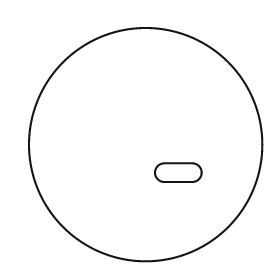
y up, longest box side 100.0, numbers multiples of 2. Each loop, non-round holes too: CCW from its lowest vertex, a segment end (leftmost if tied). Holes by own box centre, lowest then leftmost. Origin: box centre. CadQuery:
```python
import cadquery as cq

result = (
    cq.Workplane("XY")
    .moveTo(0.0, 0.0)
    .circle(50.0)
    .moveTo(8.0, -16.0)
    .lineTo(20.0, -16.0)
    .threePointArc((24.0, -12.0), (20.0, -8.0))
    .lineTo(8.0, -8.0)
    .threePointArc((4.0, -12.0), (8.0, -16.0))
    .close()
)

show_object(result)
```